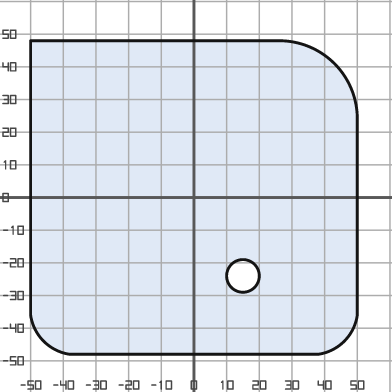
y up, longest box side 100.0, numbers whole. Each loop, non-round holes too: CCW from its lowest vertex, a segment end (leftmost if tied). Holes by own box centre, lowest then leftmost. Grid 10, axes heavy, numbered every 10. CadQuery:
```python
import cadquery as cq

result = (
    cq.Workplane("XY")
    .moveTo(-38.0, -48.0)
    .lineTo(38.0, -48.0)
    .threePointArc((46.0, -44.0), (50.0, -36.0))
    .lineTo(50.0, 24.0)
    .threePointArc((43.0, 41.0), (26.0, 48.0))
    .lineTo(-50.0, 48.0)
    .lineTo(-50.0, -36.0)
    .threePointArc((-46.0, -44.0), (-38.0, -48.0))
    .close()
    .moveTo(15.0, -24.0)
    .circle(5.0)
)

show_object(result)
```